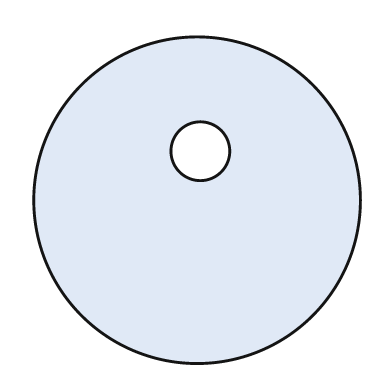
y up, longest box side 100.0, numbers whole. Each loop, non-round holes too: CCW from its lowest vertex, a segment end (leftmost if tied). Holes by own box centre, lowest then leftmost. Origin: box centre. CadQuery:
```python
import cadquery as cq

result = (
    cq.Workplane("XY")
    .moveTo(0.0, 0.0)
    .circle(50.0)
    .moveTo(1.0, 15.0)
    .circle(9.0)
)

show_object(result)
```